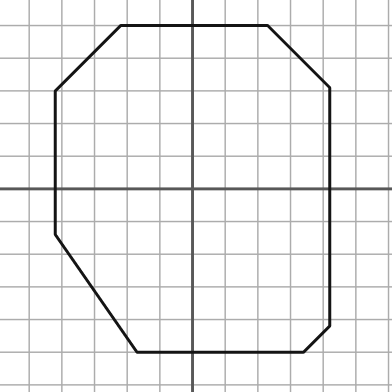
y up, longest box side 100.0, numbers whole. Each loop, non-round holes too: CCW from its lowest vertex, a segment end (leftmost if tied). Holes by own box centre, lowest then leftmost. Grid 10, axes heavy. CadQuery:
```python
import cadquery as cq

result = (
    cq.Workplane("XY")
    .moveTo(-17.0, -50.0)
    .lineTo(34.0, -50.0)
    .lineTo(42.0, -42.0)
    .lineTo(42.0, 31.0)
    .lineTo(23.0, 50.0)
    .lineTo(-22.0, 50.0)
    .lineTo(-42.0, 30.0)
    .lineTo(-42.0, -14.0)
    .close()
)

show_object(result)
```